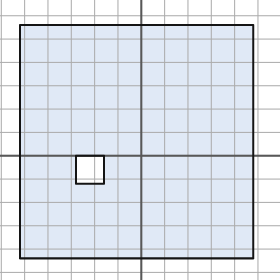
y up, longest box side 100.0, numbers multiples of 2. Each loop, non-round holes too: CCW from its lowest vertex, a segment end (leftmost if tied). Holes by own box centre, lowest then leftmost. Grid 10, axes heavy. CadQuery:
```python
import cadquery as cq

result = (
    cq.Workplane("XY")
    .moveTo(-52.0, -44.0)
    .lineTo(48.0, -44.0)
    .lineTo(48.0, 56.0)
    .lineTo(-52.0, 56.0)
    .close()
    .moveTo(-28.0, -12.0)
    .lineTo(-16.0, -12.0)
    .lineTo(-16.0, 0.0)
    .lineTo(-28.0, 0.0)
    .close()
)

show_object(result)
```